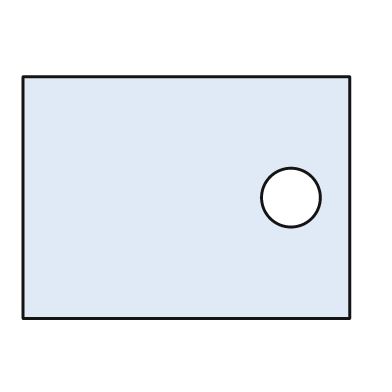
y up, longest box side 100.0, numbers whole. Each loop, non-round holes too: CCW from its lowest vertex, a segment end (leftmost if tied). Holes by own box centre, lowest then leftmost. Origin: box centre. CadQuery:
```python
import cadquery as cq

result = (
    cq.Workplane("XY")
    .moveTo(-50.0, -37.0)
    .lineTo(50.0, -37.0)
    .lineTo(50.0, 37.0)
    .lineTo(-50.0, 37.0)
    .close()
    .moveTo(32.0, 0.0)
    .circle(9.0)
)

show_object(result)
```